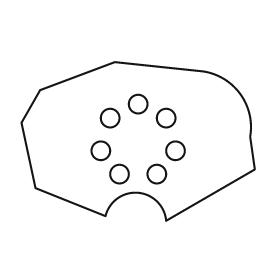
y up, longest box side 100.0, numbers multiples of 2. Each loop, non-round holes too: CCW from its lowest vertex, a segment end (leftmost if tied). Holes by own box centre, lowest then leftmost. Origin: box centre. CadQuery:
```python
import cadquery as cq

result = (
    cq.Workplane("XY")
    .moveTo(12.0, -34.0)
    .lineTo(50.0, -12.0)
    .lineTo(48.0, 2.0)
    .threePointArc((44.0, 20.0), (28.0, 30.0))
    .lineTo(-10.0, 34.0)
    .lineTo(-42.0, 22.0)
    .lineTo(-50.0, 8.0)
    .lineTo(-44.0, -20.0)
    .lineTo(-14.0, -32.0)
    .threePointArc((0.0, -22.0), (12.0, -34.0))
    .close()
    .moveTo(-8.0, -14.0)
    .circle(4.0)
    .moveTo(8.0, -14.0)
    .circle(4.0)
    .moveTo(-16.0, -4.0)
    .circle(4.0)
    .moveTo(16.0, -4.0)
    .circle(4.0)
    .moveTo(-12.0, 10.0)
    .circle(4.0)
    .moveTo(12.0, 10.0)
    .circle(4.0)
    .moveTo(0.0, 16.0)
    .circle(4.0)
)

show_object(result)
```